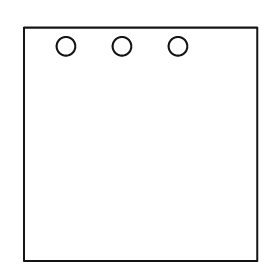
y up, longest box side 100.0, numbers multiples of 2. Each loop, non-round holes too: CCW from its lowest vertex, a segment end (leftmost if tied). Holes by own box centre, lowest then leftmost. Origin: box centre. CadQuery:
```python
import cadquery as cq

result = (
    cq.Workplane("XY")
    .moveTo(-50.0, -50.0)
    .lineTo(50.0, -50.0)
    .lineTo(50.0, 50.0)
    .lineTo(-50.0, 50.0)
    .close()
    .moveTo(-32.0, 42.0)
    .circle(4.0)
    .moveTo(-8.0, 42.0)
    .circle(4.0)
    .moveTo(16.0, 42.0)
    .circle(4.0)
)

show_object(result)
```